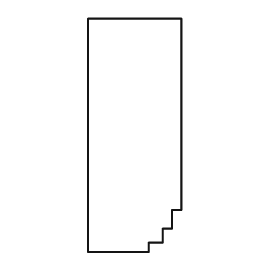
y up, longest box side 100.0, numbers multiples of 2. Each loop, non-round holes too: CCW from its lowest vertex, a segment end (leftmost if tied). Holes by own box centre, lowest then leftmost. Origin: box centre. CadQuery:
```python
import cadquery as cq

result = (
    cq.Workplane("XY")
    .moveTo(-20.0, -50.0)
    .lineTo(6.0, -50.0)
    .lineTo(6.0, -46.0)
    .lineTo(12.0, -46.0)
    .lineTo(12.0, -40.0)
    .lineTo(16.0, -40.0)
    .lineTo(16.0, -32.0)
    .lineTo(20.0, -32.0)
    .lineTo(20.0, 50.0)
    .lineTo(-20.0, 50.0)
    .close()
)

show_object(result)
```